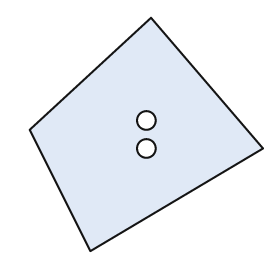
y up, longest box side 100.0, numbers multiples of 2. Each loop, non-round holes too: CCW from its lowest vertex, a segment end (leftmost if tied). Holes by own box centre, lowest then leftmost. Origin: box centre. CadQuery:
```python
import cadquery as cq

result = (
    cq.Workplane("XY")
    .moveTo(-24.0, -50.0)
    .lineTo(50.0, -6.0)
    .lineTo(2.0, 50.0)
    .lineTo(-50.0, 2.0)
    .close()
    .moveTo(0.0, -6.0)
    .circle(4.0)
    .moveTo(0.0, 6.0)
    .circle(4.0)
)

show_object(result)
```